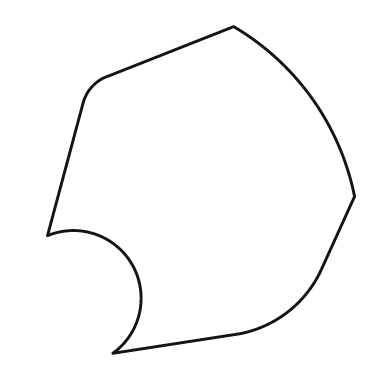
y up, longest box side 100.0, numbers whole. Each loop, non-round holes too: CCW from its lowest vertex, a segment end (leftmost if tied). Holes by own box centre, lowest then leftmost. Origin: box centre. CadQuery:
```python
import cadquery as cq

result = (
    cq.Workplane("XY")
    .moveTo(-27.0, -50.0)
    .lineTo(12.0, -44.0)
    .threePointArc((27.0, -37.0), (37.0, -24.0))
    .lineTo(47.0, -2.0)
    .threePointArc((34.0, 28.0), (10.0, 50.0))
    .lineTo(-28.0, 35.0)
    .threePointArc((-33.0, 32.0), (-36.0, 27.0))
    .lineTo(-47.0, -14.0)
    .threePointArc((-21.0, -23.0), (-27.0, -50.0))
    .close()
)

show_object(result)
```